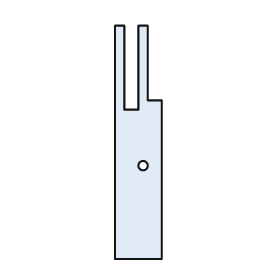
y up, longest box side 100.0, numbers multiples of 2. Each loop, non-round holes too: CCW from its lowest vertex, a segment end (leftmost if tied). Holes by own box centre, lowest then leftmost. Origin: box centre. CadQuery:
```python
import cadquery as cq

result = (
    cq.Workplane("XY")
    .moveTo(-10.0, -50.0)
    .lineTo(10.0, -50.0)
    .lineTo(10.0, 18.0)
    .lineTo(4.0, 18.0)
    .lineTo(4.0, 50.0)
    .lineTo(0.0, 50.0)
    .lineTo(0.0, 14.0)
    .lineTo(-6.0, 14.0)
    .lineTo(-6.0, 50.0)
    .lineTo(-10.0, 50.0)
    .close()
    .moveTo(2.0, -10.0)
    .circle(2.0)
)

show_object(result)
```